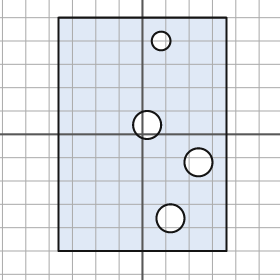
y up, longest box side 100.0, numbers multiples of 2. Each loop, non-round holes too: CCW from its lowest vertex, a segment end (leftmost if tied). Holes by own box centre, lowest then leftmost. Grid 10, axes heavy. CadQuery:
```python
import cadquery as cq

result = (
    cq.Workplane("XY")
    .moveTo(-36.0, -50.0)
    .lineTo(36.0, -50.0)
    .lineTo(36.0, 50.0)
    .lineTo(-36.0, 50.0)
    .close()
    .moveTo(12.0, -36.0)
    .circle(6.0)
    .moveTo(24.0, -12.0)
    .circle(6.0)
    .moveTo(2.0, 4.0)
    .circle(6.0)
    .moveTo(8.0, 40.0)
    .circle(4.0)
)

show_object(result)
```